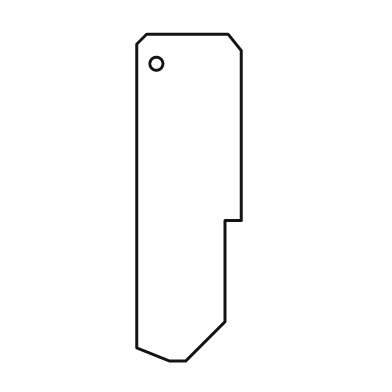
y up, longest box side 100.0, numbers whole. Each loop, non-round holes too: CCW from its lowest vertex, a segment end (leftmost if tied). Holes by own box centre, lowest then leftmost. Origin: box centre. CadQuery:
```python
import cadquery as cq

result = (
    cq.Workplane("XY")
    .moveTo(-6.0, -50.0)
    .lineTo(-1.0, -50.0)
    .lineTo(11.0, -38.0)
    .lineTo(11.0, -7.0)
    .lineTo(16.0, -7.0)
    .lineTo(16.0, 45.0)
    .lineTo(12.0, 50.0)
    .lineTo(-13.0, 50.0)
    .lineTo(-16.0, 47.0)
    .lineTo(-16.0, -46.0)
    .close()
    .moveTo(-10.0, 41.0)
    .circle(2.0)
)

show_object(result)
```